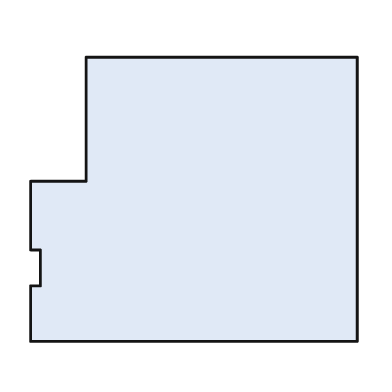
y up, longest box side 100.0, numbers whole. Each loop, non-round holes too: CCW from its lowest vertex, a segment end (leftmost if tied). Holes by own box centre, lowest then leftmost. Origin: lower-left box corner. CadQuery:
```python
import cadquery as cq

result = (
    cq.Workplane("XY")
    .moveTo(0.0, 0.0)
    .lineTo(100.0, 0.0)
    .lineTo(100.0, 87.0)
    .lineTo(17.0, 87.0)
    .lineTo(17.0, 49.0)
    .lineTo(0.0, 49.0)
    .lineTo(0.0, 28.0)
    .lineTo(3.0, 28.0)
    .lineTo(3.0, 17.0)
    .lineTo(0.0, 17.0)
    .close()
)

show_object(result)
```